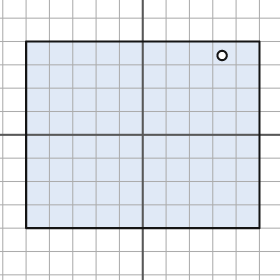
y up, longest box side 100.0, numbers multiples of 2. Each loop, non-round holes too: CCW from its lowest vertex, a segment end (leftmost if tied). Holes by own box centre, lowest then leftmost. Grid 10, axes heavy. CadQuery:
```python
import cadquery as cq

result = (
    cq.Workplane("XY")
    .moveTo(-50.0, -40.0)
    .lineTo(50.0, -40.0)
    .lineTo(50.0, 40.0)
    .lineTo(-50.0, 40.0)
    .close()
    .moveTo(34.0, 34.0)
    .circle(2.0)
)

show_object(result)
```